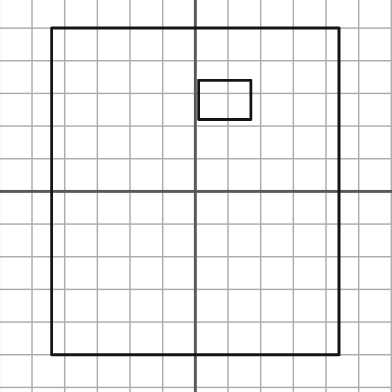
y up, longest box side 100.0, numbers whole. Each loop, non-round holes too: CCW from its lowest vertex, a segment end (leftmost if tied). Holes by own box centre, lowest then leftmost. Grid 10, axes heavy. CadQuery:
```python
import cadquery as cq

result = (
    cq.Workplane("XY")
    .moveTo(-44.0, -50.0)
    .lineTo(44.0, -50.0)
    .lineTo(44.0, 50.0)
    .lineTo(-44.0, 50.0)
    .close()
    .moveTo(1.0, 22.0)
    .lineTo(17.0, 22.0)
    .lineTo(17.0, 34.0)
    .lineTo(1.0, 34.0)
    .close()
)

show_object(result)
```